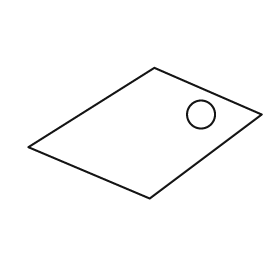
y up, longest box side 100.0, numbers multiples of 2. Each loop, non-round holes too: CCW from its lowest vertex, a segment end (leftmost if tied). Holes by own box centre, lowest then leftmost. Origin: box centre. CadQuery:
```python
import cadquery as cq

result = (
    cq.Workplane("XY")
    .moveTo(2.0, -28.0)
    .lineTo(50.0, 8.0)
    .lineTo(4.0, 28.0)
    .lineTo(-50.0, -6.0)
    .close()
    .moveTo(24.0, 8.0)
    .circle(6.0)
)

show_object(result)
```